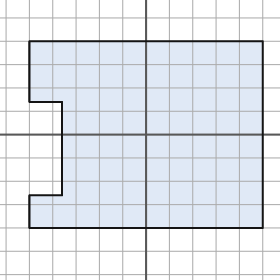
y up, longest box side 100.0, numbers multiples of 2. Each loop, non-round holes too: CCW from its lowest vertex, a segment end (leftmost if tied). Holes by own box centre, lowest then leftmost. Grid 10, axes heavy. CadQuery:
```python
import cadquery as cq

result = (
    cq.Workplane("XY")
    .moveTo(-50.0, -40.0)
    .lineTo(50.0, -40.0)
    .lineTo(50.0, 40.0)
    .lineTo(-50.0, 40.0)
    .lineTo(-50.0, 14.0)
    .lineTo(-36.0, 14.0)
    .lineTo(-36.0, -26.0)
    .lineTo(-50.0, -26.0)
    .close()
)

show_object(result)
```